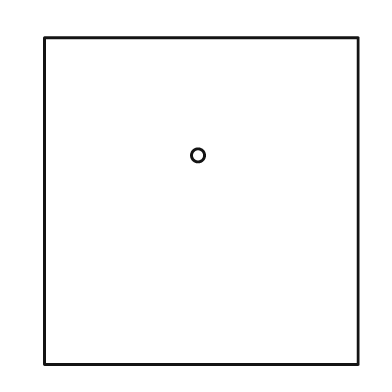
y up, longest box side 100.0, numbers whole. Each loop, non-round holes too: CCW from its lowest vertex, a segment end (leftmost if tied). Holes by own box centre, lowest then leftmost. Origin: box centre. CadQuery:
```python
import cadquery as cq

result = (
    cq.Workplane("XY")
    .moveTo(-48.0, -50.0)
    .lineTo(48.0, -50.0)
    .lineTo(48.0, 50.0)
    .lineTo(-48.0, 50.0)
    .close()
    .moveTo(-1.0, 14.0)
    .circle(2.0)
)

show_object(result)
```